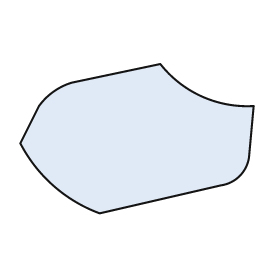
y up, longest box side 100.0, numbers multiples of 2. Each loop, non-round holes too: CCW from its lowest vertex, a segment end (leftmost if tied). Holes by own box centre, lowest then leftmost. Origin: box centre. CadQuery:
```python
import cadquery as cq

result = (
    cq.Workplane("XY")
    .moveTo(-16.0, -32.0)
    .lineTo(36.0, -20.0)
    .threePointArc((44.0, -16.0), (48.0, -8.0))
    .lineTo(50.0, 14.0)
    .threePointArc((28.0, 18.0), (10.0, 32.0))
    .lineTo(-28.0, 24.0)
    .threePointArc((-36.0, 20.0), (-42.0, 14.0))
    .lineTo(-50.0, -2.0)
    .threePointArc((-36.0, -20.0), (-16.0, -32.0))
    .close()
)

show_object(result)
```